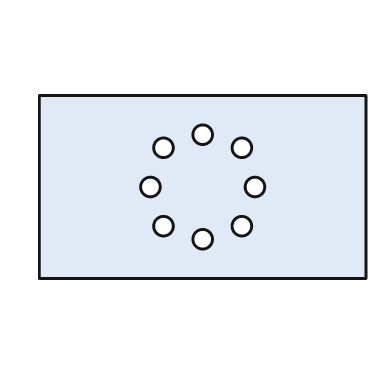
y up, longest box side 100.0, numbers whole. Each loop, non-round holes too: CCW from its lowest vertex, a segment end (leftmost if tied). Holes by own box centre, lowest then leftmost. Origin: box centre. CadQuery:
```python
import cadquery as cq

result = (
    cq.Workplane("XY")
    .moveTo(-50.0, -28.0)
    .lineTo(50.0, -28.0)
    .lineTo(50.0, 28.0)
    .lineTo(-50.0, 28.0)
    .close()
    .moveTo(0.0, -16.0)
    .circle(3.0)
    .moveTo(-12.0, -12.0)
    .circle(3.0)
    .moveTo(12.0, -12.0)
    .circle(3.0)
    .moveTo(-16.0, 0.0)
    .circle(3.0)
    .moveTo(16.0, 0.0)
    .circle(3.0)
    .moveTo(-12.0, 12.0)
    .circle(3.0)
    .moveTo(12.0, 12.0)
    .circle(3.0)
    .moveTo(0.0, 16.0)
    .circle(3.0)
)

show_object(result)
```